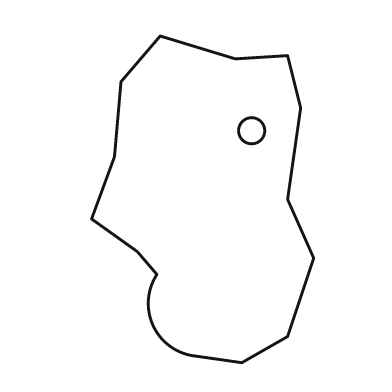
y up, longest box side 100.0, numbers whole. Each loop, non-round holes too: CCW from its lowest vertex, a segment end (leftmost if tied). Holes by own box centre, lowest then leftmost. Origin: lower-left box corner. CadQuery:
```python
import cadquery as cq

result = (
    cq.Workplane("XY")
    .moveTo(46.0, 0.0)
    .lineTo(60.0, 8.0)
    .lineTo(68.0, 32.0)
    .lineTo(60.0, 50.0)
    .lineTo(64.0, 78.0)
    .lineTo(60.0, 94.0)
    .lineTo(44.0, 93.0)
    .lineTo(21.0, 100.0)
    .lineTo(9.0, 86.0)
    .lineTo(7.0, 63.0)
    .lineTo(0.0, 44.0)
    .lineTo(14.0, 34.0)
    .lineTo(20.0, 27.0)
    .threePointArc((19.0, 11.0), (32.0, 2.0))
    .close()
    .moveTo(49.0, 71.0)
    .circle(4.0)
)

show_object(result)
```